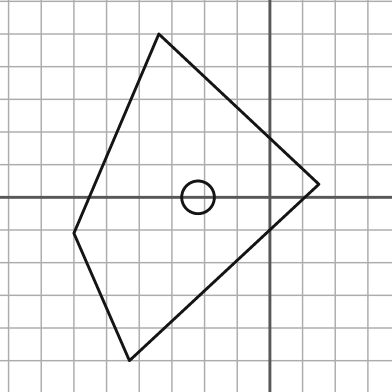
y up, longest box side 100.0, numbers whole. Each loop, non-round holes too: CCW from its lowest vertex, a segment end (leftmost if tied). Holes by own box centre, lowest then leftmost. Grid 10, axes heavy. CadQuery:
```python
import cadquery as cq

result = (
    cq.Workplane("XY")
    .moveTo(-43.0, -50.0)
    .lineTo(15.0, 4.0)
    .lineTo(-34.0, 50.0)
    .lineTo(-60.0, -11.0)
    .close()
    .moveTo(-22.0, 0.0)
    .circle(5.0)
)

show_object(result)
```